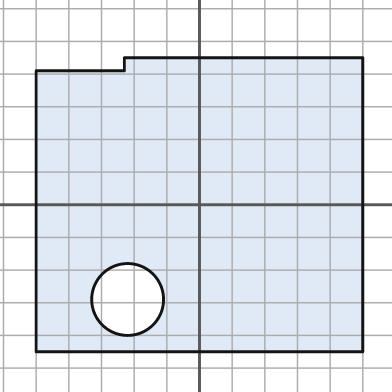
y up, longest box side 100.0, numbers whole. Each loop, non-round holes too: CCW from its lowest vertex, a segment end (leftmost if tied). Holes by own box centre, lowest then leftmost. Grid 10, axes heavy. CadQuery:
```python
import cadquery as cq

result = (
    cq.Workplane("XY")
    .moveTo(-50.0, -45.0)
    .lineTo(50.0, -45.0)
    .lineTo(50.0, 45.0)
    .lineTo(-23.0, 45.0)
    .lineTo(-23.0, 41.0)
    .lineTo(-50.0, 41.0)
    .close()
    .moveTo(-22.0, -29.0)
    .circle(11.0)
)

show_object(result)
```